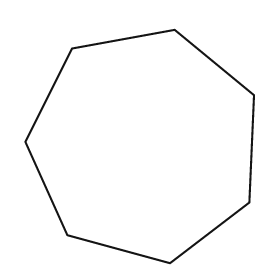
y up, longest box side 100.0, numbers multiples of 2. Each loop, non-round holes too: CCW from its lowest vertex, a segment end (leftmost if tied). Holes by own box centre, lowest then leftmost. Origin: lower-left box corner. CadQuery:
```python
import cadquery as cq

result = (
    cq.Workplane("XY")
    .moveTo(62.0, 0.0)
    .lineTo(96.0, 26.0)
    .lineTo(98.0, 72.0)
    .lineTo(64.0, 100.0)
    .lineTo(20.0, 92.0)
    .lineTo(0.0, 52.0)
    .lineTo(18.0, 12.0)
    .close()
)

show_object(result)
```